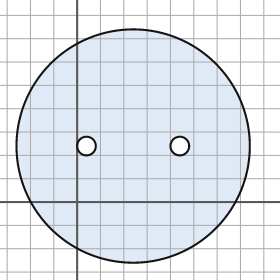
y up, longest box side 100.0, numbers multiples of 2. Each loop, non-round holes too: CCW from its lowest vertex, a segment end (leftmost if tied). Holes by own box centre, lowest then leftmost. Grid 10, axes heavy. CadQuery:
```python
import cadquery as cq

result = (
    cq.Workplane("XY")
    .moveTo(24.0, 24.0)
    .circle(50.0)
    .moveTo(4.0, 24.0)
    .circle(4.0)
    .moveTo(44.0, 24.0)
    .circle(4.0)
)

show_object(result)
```